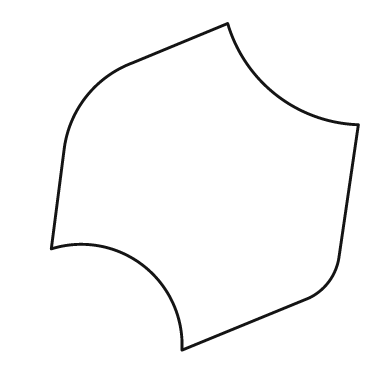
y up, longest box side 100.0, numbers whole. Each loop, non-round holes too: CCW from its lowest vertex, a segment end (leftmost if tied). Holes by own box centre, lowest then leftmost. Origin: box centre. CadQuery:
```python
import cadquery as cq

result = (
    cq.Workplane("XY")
    .moveTo(-7.0, -50.0)
    .lineTo(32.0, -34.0)
    .threePointArc((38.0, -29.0), (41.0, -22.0))
    .lineTo(47.0, 19.0)
    .threePointArc((22.0, 28.0), (7.0, 50.0))
    .lineTo(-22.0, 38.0)
    .threePointArc((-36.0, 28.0), (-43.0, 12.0))
    .lineTo(-47.0, -19.0)
    .threePointArc((-19.0, -24.0), (-7.0, -50.0))
    .close()
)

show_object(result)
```